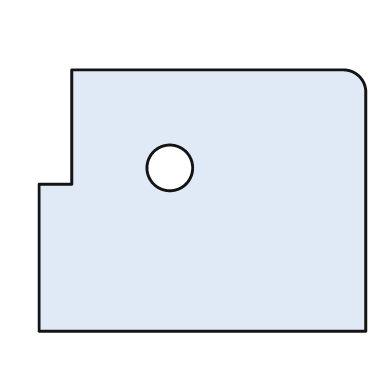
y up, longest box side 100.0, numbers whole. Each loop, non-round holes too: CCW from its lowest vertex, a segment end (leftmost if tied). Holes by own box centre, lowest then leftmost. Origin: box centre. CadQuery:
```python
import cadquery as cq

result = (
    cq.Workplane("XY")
    .moveTo(-50.0, -40.0)
    .lineTo(50.0, -40.0)
    .lineTo(50.0, 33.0)
    .threePointArc((48.0, 38.0), (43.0, 40.0))
    .lineTo(-40.0, 40.0)
    .lineTo(-40.0, 5.0)
    .lineTo(-50.0, 5.0)
    .close()
    .moveTo(-10.0, 10.0)
    .circle(7.0)
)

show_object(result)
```